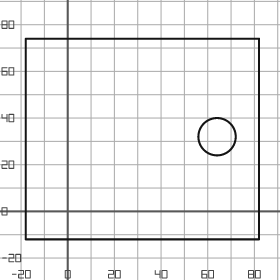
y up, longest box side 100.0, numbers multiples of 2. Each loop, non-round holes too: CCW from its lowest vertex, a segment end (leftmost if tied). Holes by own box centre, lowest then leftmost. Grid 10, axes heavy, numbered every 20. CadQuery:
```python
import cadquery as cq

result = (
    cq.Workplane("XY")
    .moveTo(-18.0, -12.0)
    .lineTo(82.0, -12.0)
    .lineTo(82.0, 74.0)
    .lineTo(-18.0, 74.0)
    .close()
    .moveTo(64.0, 32.0)
    .circle(8.0)
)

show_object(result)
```